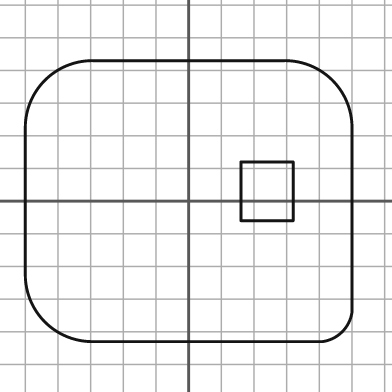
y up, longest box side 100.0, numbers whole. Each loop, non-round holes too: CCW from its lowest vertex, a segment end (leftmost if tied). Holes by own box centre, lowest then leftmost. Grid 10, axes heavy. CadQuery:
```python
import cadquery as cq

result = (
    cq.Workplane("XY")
    .moveTo(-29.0, -43.0)
    .lineTo(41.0, -43.0)
    .threePointArc((47.0, -40.0), (50.0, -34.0))
    .lineTo(50.0, 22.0)
    .threePointArc((44.0, 37.0), (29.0, 43.0))
    .lineTo(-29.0, 43.0)
    .threePointArc((-44.0, 37.0), (-50.0, 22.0))
    .lineTo(-50.0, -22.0)
    .threePointArc((-44.0, -37.0), (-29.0, -43.0))
    .close()
    .moveTo(16.0, -6.0)
    .lineTo(32.0, -6.0)
    .lineTo(32.0, 12.0)
    .lineTo(16.0, 12.0)
    .close()
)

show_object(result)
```